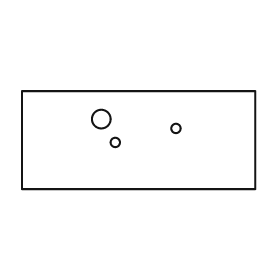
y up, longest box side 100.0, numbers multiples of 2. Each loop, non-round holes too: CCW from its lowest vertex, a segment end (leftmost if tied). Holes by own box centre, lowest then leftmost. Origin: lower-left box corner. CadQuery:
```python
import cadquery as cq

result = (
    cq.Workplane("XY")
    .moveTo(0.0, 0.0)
    .lineTo(100.0, 0.0)
    .lineTo(100.0, 42.0)
    .lineTo(0.0, 42.0)
    .close()
    .moveTo(40.0, 20.0)
    .circle(2.0)
    .moveTo(66.0, 26.0)
    .circle(2.0)
    .moveTo(34.0, 30.0)
    .circle(4.0)
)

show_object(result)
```